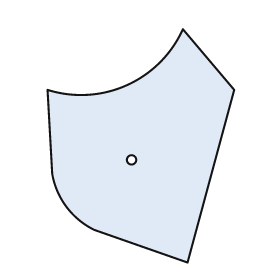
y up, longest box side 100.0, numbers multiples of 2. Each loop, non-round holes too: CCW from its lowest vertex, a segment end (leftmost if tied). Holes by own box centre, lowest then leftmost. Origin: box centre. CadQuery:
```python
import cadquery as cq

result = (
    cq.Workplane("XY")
    .moveTo(20.0, -50.0)
    .lineTo(40.0, 24.0)
    .lineTo(18.0, 50.0)
    .threePointArc((-6.0, 26.0), (-40.0, 24.0))
    .lineTo(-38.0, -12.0)
    .threePointArc((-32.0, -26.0), (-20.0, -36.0))
    .close()
    .moveTo(-4.0, -6.0)
    .circle(2.0)
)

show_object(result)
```